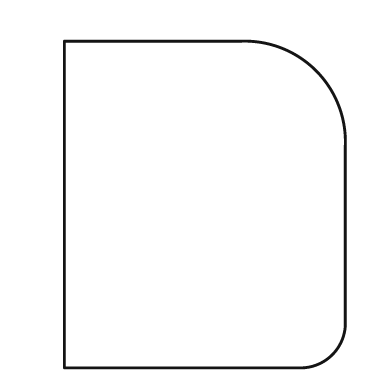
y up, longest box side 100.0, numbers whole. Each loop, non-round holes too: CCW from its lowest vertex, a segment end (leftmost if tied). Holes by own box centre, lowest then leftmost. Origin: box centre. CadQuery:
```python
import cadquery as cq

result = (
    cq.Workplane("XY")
    .moveTo(-43.0, -50.0)
    .lineTo(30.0, -50.0)
    .threePointArc((39.0, -46.0), (43.0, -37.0))
    .lineTo(43.0, 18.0)
    .threePointArc((34.0, 41.0), (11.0, 50.0))
    .lineTo(-43.0, 50.0)
    .close()
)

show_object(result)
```